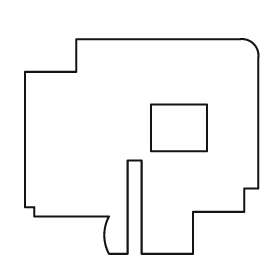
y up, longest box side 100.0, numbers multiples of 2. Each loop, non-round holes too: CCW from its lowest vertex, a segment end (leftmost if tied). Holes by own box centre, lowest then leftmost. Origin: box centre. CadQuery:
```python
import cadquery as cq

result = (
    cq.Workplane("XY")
    .moveTo(-14.0, -46.0)
    .lineTo(-6.0, -46.0)
    .lineTo(-6.0, -6.0)
    .lineTo(0.0, -6.0)
    .lineTo(0.0, -46.0)
    .lineTo(22.0, -46.0)
    .lineTo(22.0, -28.0)
    .lineTo(44.0, -28.0)
    .lineTo(44.0, -18.0)
    .lineTo(50.0, -18.0)
    .lineTo(50.0, 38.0)
    .threePointArc((48.0, 44.0), (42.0, 46.0))
    .lineTo(-28.0, 46.0)
    .lineTo(-28.0, 32.0)
    .lineTo(-50.0, 32.0)
    .lineTo(-50.0, -26.0)
    .lineTo(-46.0, -26.0)
    .lineTo(-46.0, -30.0)
    .lineTo(-14.0, -30.0)
    .threePointArc((-16.0, -38.0), (-14.0, -46.0))
    .close()
    .moveTo(4.0, -2.0)
    .lineTo(28.0, -2.0)
    .lineTo(28.0, 18.0)
    .lineTo(4.0, 18.0)
    .close()
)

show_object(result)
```